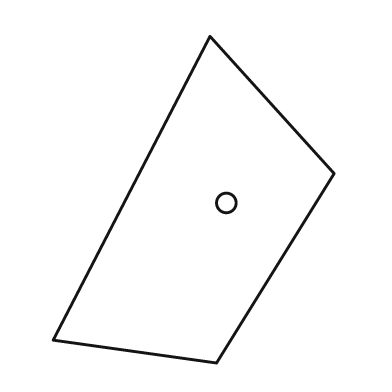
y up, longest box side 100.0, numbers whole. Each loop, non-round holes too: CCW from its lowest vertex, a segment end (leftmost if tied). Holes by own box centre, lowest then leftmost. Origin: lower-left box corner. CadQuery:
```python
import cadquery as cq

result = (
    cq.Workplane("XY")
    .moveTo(50.0, 0.0)
    .lineTo(86.0, 58.0)
    .lineTo(48.0, 100.0)
    .lineTo(0.0, 7.0)
    .close()
    .moveTo(53.0, 49.0)
    .circle(3.0)
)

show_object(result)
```